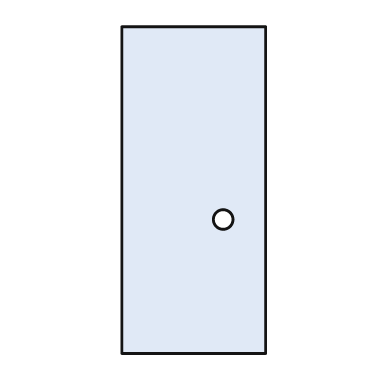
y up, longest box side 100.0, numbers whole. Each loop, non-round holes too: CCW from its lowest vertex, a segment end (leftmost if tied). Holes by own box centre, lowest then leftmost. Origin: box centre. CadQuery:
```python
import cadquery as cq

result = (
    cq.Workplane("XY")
    .moveTo(-22.0, -50.0)
    .lineTo(22.0, -50.0)
    .lineTo(22.0, 50.0)
    .lineTo(-22.0, 50.0)
    .close()
    .moveTo(9.0, -9.0)
    .circle(3.0)
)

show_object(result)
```